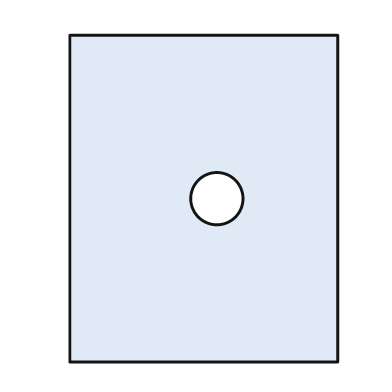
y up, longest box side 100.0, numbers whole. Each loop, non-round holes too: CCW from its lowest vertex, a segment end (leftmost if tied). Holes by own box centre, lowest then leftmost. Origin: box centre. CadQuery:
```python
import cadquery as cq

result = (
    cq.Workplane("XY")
    .moveTo(-41.0, -50.0)
    .lineTo(41.0, -50.0)
    .lineTo(41.0, 50.0)
    .lineTo(-41.0, 50.0)
    .close()
    .moveTo(4.0, 0.0)
    .circle(8.0)
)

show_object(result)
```